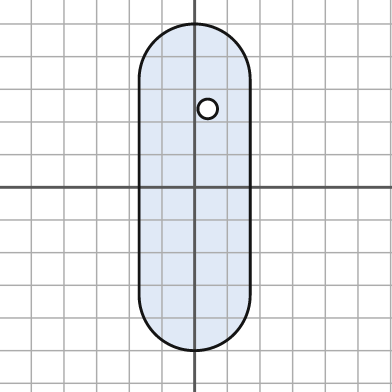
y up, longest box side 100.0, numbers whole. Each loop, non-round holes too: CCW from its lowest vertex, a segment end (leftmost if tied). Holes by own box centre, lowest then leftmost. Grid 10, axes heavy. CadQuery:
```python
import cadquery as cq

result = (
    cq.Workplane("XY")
    .moveTo(-17.0, -33.0)
    .threePointArc((0.0, -50.0), (17.0, -33.0))
    .lineTo(17.0, 33.0)
    .threePointArc((0.0, 50.0), (-17.0, 33.0))
    .close()
    .moveTo(4.0, 24.0)
    .circle(3.0)
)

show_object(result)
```